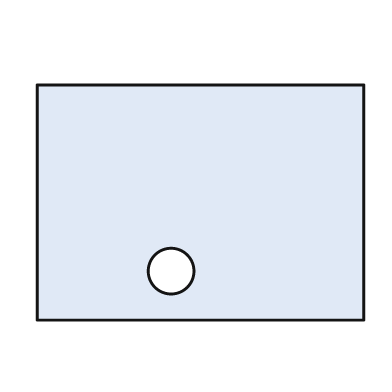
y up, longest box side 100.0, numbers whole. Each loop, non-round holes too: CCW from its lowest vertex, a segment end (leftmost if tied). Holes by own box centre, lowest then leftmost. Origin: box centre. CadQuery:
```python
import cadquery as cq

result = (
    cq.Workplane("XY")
    .moveTo(-50.0, -36.0)
    .lineTo(50.0, -36.0)
    .lineTo(50.0, 36.0)
    .lineTo(-50.0, 36.0)
    .close()
    .moveTo(-9.0, -21.0)
    .circle(7.0)
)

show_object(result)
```